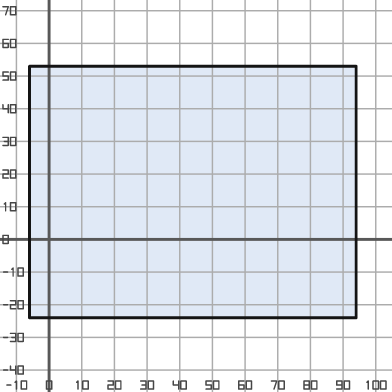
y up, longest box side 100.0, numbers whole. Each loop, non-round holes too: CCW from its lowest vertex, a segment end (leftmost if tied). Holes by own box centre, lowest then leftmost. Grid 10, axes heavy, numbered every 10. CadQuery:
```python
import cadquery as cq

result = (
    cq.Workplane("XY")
    .moveTo(-6.0, -24.0)
    .lineTo(94.0, -24.0)
    .lineTo(94.0, 53.0)
    .lineTo(-6.0, 53.0)
    .close()
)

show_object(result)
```